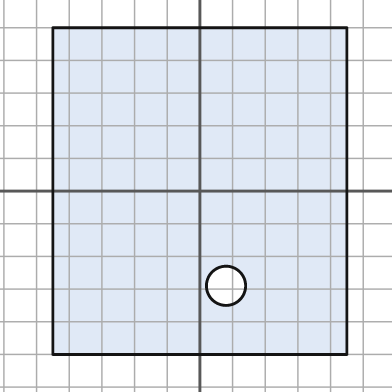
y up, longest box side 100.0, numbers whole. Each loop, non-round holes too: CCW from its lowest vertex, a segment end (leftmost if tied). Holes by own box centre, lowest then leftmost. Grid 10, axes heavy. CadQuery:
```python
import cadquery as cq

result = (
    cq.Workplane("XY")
    .moveTo(-45.0, -50.0)
    .lineTo(45.0, -50.0)
    .lineTo(45.0, 50.0)
    .lineTo(-45.0, 50.0)
    .close()
    .moveTo(8.0, -29.0)
    .circle(6.0)
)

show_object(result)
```